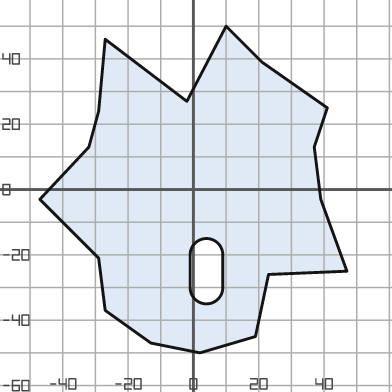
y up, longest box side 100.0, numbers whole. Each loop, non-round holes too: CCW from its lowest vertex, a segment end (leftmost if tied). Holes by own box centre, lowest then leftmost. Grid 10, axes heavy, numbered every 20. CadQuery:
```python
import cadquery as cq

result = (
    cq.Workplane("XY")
    .moveTo(2.0, -50.0)
    .lineTo(19.0, -45.0)
    .lineTo(23.0, -26.0)
    .lineTo(47.0, -25.0)
    .lineTo(39.0, -3.0)
    .lineTo(37.0, 13.0)
    .lineTo(41.0, 25.0)
    .lineTo(21.0, 39.0)
    .lineTo(10.0, 50.0)
    .lineTo(-2.0, 27.0)
    .lineTo(-27.0, 46.0)
    .lineTo(-29.0, 24.0)
    .lineTo(-32.0, 13.0)
    .lineTo(-47.0, -3.0)
    .lineTo(-29.0, -21.0)
    .lineTo(-27.0, -37.0)
    .lineTo(-13.0, -47.0)
    .close()
    .moveTo(-1.0, -30.0)
    .threePointArc((4.0, -35.0), (9.0, -30.0))
    .lineTo(9.0, -20.0)
    .threePointArc((4.0, -15.0), (-1.0, -20.0))
    .close()
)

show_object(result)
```